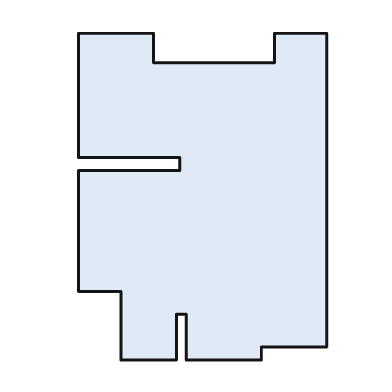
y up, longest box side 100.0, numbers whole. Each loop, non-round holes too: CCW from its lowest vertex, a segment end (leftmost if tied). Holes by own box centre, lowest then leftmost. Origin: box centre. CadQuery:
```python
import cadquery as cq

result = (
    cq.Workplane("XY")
    .moveTo(-25.0, -50.0)
    .lineTo(-8.0, -50.0)
    .lineTo(-8.0, -36.0)
    .lineTo(-5.0, -36.0)
    .lineTo(-5.0, -50.0)
    .lineTo(18.0, -50.0)
    .lineTo(18.0, -46.0)
    .lineTo(38.0, -46.0)
    .lineTo(38.0, 50.0)
    .lineTo(22.0, 50.0)
    .lineTo(22.0, 41.0)
    .lineTo(-15.0, 41.0)
    .lineTo(-15.0, 50.0)
    .lineTo(-38.0, 50.0)
    .lineTo(-38.0, 12.0)
    .lineTo(-7.0, 12.0)
    .lineTo(-7.0, 8.0)
    .lineTo(-38.0, 8.0)
    .lineTo(-38.0, -29.0)
    .lineTo(-25.0, -29.0)
    .close()
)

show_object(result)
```